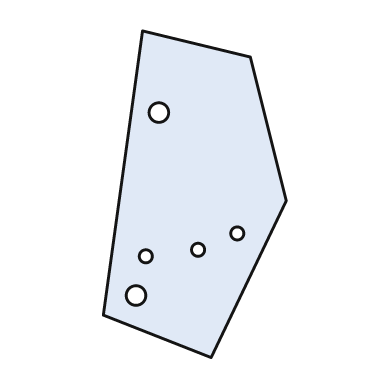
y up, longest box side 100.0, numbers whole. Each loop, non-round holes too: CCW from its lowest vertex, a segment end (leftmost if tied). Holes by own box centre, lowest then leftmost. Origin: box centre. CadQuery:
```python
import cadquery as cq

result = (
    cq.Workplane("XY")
    .moveTo(5.0, -50.0)
    .lineTo(28.0, -2.0)
    .lineTo(17.0, 42.0)
    .lineTo(-16.0, 50.0)
    .lineTo(-28.0, -37.0)
    .close()
    .moveTo(-18.0, -31.0)
    .circle(3.0)
    .moveTo(-15.0, -19.0)
    .circle(2.0)
    .moveTo(1.0, -17.0)
    .circle(2.0)
    .moveTo(13.0, -12.0)
    .circle(2.0)
    .moveTo(-11.0, 25.0)
    .circle(3.0)
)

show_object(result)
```